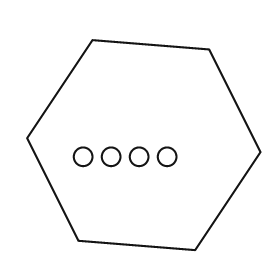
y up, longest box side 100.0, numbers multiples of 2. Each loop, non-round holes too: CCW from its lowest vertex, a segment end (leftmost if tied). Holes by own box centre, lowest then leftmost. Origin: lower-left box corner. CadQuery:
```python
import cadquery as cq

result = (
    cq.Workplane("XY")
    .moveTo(72.0, 0.0)
    .lineTo(100.0, 42.0)
    .lineTo(78.0, 86.0)
    .lineTo(28.0, 90.0)
    .lineTo(0.0, 48.0)
    .lineTo(22.0, 4.0)
    .close()
    .moveTo(24.0, 40.0)
    .circle(4.0)
    .moveTo(36.0, 40.0)
    .circle(4.0)
    .moveTo(48.0, 40.0)
    .circle(4.0)
    .moveTo(60.0, 40.0)
    .circle(4.0)
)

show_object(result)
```